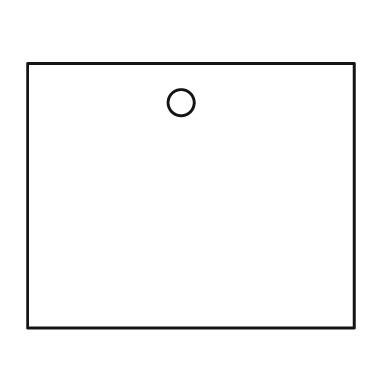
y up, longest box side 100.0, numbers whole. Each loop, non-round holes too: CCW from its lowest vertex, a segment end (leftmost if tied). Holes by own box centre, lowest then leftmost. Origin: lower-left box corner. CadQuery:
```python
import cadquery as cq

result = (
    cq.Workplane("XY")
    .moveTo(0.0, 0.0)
    .lineTo(100.0, 0.0)
    .lineTo(100.0, 81.0)
    .lineTo(0.0, 81.0)
    .close()
    .moveTo(47.0, 69.0)
    .circle(4.0)
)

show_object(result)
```